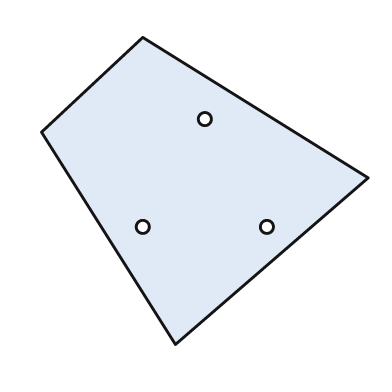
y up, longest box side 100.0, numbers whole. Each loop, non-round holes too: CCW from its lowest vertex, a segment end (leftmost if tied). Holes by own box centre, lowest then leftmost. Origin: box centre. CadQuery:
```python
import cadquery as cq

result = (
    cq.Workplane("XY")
    .moveTo(-9.0, -47.0)
    .lineTo(50.0, 4.0)
    .lineTo(-19.0, 47.0)
    .lineTo(-50.0, 18.0)
    .close()
    .moveTo(-19.0, -11.0)
    .circle(2.0)
    .moveTo(19.0, -11.0)
    .circle(2.0)
    .moveTo(0.0, 22.0)
    .circle(2.0)
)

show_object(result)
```